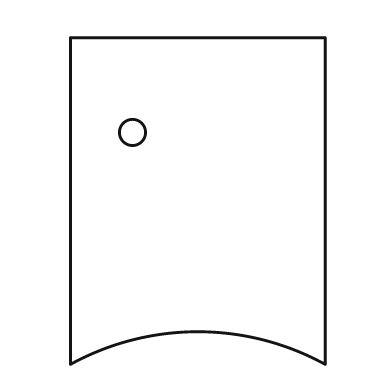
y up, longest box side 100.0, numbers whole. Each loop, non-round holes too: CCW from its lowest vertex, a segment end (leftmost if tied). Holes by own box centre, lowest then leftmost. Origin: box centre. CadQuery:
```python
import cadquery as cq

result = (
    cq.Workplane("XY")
    .moveTo(-39.0, -50.0)
    .threePointArc((0.0, -40.0), (39.0, -50.0))
    .lineTo(39.0, 50.0)
    .lineTo(-39.0, 50.0)
    .close()
    .moveTo(-20.0, 21.0)
    .circle(4.0)
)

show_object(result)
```